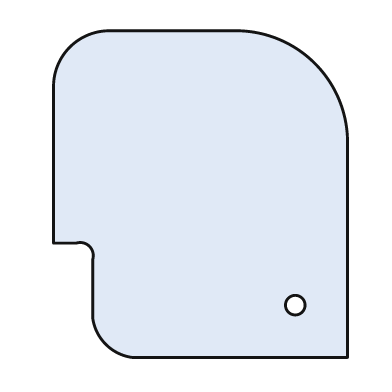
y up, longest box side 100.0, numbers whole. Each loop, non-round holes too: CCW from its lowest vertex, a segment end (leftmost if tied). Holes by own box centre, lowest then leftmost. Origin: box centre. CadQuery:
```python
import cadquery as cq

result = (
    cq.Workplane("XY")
    .moveTo(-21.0, -50.0)
    .lineTo(45.0, -50.0)
    .lineTo(45.0, 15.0)
    .threePointArc((35.0, 40.0), (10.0, 50.0))
    .lineTo(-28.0, 50.0)
    .threePointArc((-40.0, 45.0), (-45.0, 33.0))
    .lineTo(-45.0, -15.0)
    .lineTo(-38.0, -15.0)
    .threePointArc((-34.0, -16.0), (-33.0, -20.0))
    .lineTo(-33.0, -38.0)
    .threePointArc((-29.0, -46.0), (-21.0, -50.0))
    .close()
    .moveTo(29.0, -34.0)
    .circle(3.0)
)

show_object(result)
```